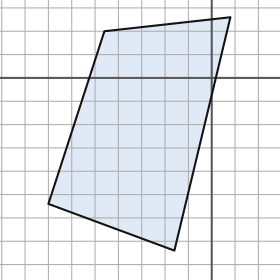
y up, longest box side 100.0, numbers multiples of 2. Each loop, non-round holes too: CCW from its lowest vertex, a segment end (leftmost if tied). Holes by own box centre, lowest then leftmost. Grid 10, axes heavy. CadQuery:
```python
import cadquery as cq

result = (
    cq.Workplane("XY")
    .moveTo(-16.0, -74.0)
    .lineTo(8.0, 26.0)
    .lineTo(-46.0, 20.0)
    .lineTo(-70.0, -54.0)
    .close()
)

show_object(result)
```